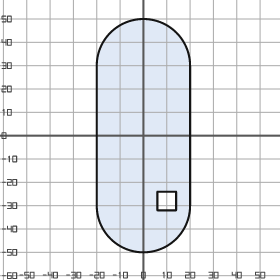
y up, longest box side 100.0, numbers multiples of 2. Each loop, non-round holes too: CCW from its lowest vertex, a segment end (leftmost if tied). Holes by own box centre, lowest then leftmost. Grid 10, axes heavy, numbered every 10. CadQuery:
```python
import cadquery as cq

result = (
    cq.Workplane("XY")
    .moveTo(-20.0, -30.0)
    .threePointArc((0.0, -50.0), (20.0, -30.0))
    .lineTo(20.0, 30.0)
    .threePointArc((0.0, 50.0), (-20.0, 30.0))
    .close()
    .moveTo(6.0, -32.0)
    .lineTo(14.0, -32.0)
    .lineTo(14.0, -24.0)
    .lineTo(6.0, -24.0)
    .close()
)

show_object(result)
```